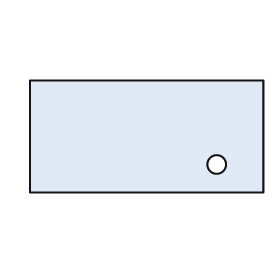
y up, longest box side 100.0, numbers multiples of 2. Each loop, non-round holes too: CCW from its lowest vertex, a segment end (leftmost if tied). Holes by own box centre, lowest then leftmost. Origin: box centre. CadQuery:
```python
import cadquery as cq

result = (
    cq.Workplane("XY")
    .moveTo(-50.0, -24.0)
    .lineTo(50.0, -24.0)
    .lineTo(50.0, 24.0)
    .lineTo(-50.0, 24.0)
    .close()
    .moveTo(30.0, -12.0)
    .circle(4.0)
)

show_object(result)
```